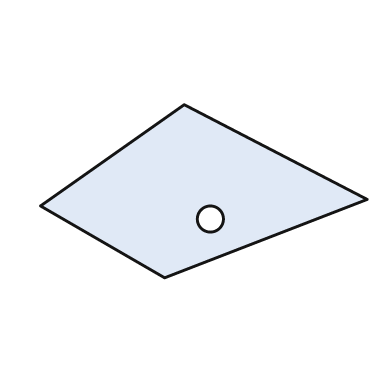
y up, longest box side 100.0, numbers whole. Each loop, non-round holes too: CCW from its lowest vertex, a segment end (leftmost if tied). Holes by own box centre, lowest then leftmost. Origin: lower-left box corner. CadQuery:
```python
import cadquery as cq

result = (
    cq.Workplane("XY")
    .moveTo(38.0, 0.0)
    .lineTo(100.0, 24.0)
    .lineTo(44.0, 53.0)
    .lineTo(0.0, 22.0)
    .close()
    .moveTo(52.0, 18.0)
    .circle(4.0)
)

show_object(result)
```